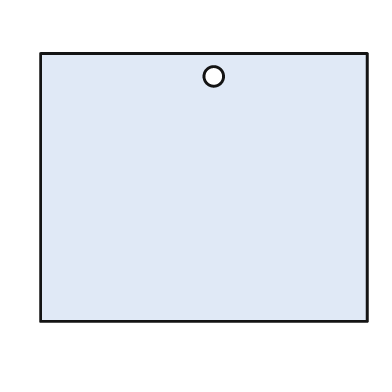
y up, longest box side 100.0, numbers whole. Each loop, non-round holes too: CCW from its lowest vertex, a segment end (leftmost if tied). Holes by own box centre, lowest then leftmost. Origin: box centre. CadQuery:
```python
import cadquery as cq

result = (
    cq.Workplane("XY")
    .moveTo(-50.0, -41.0)
    .lineTo(50.0, -41.0)
    .lineTo(50.0, 41.0)
    .lineTo(-50.0, 41.0)
    .close()
    .moveTo(3.0, 34.0)
    .circle(3.0)
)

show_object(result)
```